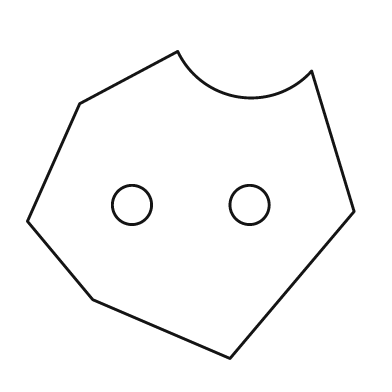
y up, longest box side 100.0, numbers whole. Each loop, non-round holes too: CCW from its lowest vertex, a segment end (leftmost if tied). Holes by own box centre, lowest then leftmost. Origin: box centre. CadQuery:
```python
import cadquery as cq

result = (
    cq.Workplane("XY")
    .moveTo(12.0, -47.0)
    .lineTo(50.0, -2.0)
    .lineTo(37.0, 41.0)
    .threePointArc((15.0, 33.0), (-4.0, 47.0))
    .lineTo(-34.0, 31.0)
    .lineTo(-50.0, -5.0)
    .lineTo(-30.0, -29.0)
    .close()
    .moveTo(-18.0, 0.0)
    .circle(6.0)
    .moveTo(18.0, 0.0)
    .circle(6.0)
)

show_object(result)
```